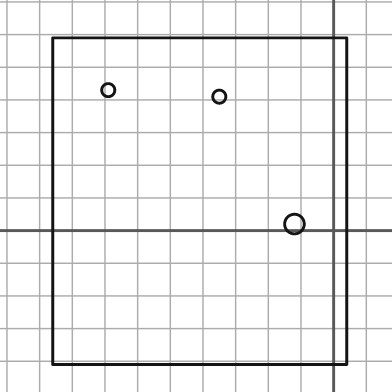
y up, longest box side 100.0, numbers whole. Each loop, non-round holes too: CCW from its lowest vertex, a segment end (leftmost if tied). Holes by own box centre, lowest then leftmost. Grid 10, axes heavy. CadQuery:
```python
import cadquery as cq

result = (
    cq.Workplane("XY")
    .moveTo(-86.0, -41.0)
    .lineTo(4.0, -41.0)
    .lineTo(4.0, 59.0)
    .lineTo(-86.0, 59.0)
    .close()
    .moveTo(-12.0, 2.0)
    .circle(3.0)
    .moveTo(-35.0, 41.0)
    .circle(2.0)
    .moveTo(-69.0, 43.0)
    .circle(2.0)
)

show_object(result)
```